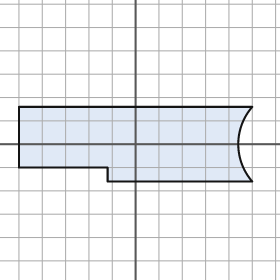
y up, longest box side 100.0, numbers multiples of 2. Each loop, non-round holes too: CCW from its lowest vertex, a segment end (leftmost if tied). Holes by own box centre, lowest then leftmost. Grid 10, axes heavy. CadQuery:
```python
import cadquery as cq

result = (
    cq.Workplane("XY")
    .moveTo(-12.0, -16.0)
    .lineTo(50.0, -16.0)
    .threePointArc((44.0, 0.0), (50.0, 16.0))
    .lineTo(-50.0, 16.0)
    .lineTo(-50.0, -10.0)
    .lineTo(-12.0, -10.0)
    .close()
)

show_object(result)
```